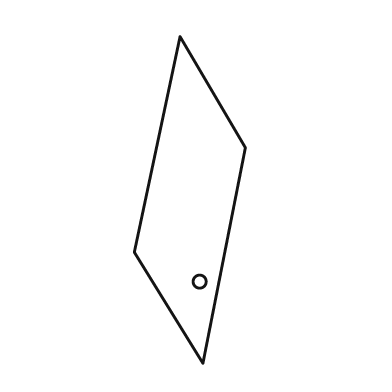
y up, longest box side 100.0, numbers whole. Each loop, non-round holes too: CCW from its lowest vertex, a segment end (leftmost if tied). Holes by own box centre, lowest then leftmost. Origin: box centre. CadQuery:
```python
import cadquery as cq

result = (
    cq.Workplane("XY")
    .moveTo(4.0, -50.0)
    .lineTo(17.0, 16.0)
    .lineTo(-3.0, 50.0)
    .lineTo(-17.0, -16.0)
    .close()
    .moveTo(3.0, -25.0)
    .circle(2.0)
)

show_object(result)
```